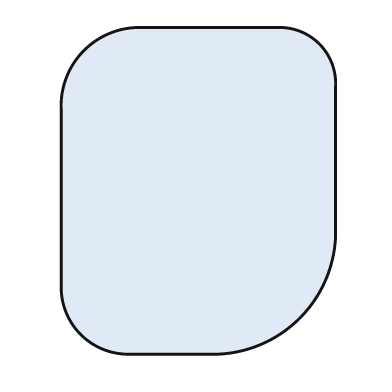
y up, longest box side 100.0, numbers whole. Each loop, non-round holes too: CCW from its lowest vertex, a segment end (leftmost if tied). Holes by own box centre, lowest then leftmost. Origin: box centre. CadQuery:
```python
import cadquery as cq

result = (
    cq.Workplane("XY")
    .moveTo(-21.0, -50.0)
    .lineTo(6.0, -50.0)
    .threePointArc((31.0, -39.0), (42.0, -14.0))
    .lineTo(42.0, 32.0)
    .threePointArc((37.0, 45.0), (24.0, 50.0))
    .lineTo(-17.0, 50.0)
    .threePointArc((-35.0, 43.0), (-42.0, 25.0))
    .lineTo(-42.0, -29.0)
    .threePointArc((-36.0, -44.0), (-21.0, -50.0))
    .close()
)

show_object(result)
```